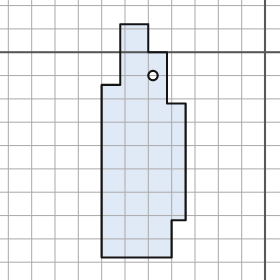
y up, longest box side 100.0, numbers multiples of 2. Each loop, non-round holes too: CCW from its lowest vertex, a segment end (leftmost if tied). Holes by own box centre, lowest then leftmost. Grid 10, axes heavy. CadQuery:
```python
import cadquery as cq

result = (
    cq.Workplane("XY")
    .moveTo(-70.0, -88.0)
    .lineTo(-40.0, -88.0)
    .lineTo(-40.0, -72.0)
    .lineTo(-34.0, -72.0)
    .lineTo(-34.0, -22.0)
    .lineTo(-42.0, -22.0)
    .lineTo(-42.0, 0.0)
    .lineTo(-50.0, 0.0)
    .lineTo(-50.0, 12.0)
    .lineTo(-62.0, 12.0)
    .lineTo(-62.0, -14.0)
    .lineTo(-70.0, -14.0)
    .close()
    .moveTo(-48.0, -10.0)
    .circle(2.0)
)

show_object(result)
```